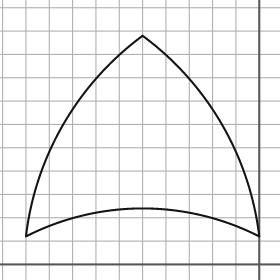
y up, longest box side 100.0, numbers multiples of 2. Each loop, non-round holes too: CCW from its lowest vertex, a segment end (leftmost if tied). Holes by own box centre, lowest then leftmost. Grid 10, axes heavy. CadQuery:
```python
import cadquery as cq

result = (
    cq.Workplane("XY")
    .moveTo(-100.0, 12.0)
    .threePointArc((-50.0, 24.0), (0.0, 12.0))
    .threePointArc((-16.0, 60.0), (-50.0, 98.0))
    .threePointArc((-84.0, 60.0), (-100.0, 12.0))
    .close()
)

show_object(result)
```